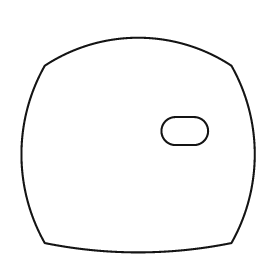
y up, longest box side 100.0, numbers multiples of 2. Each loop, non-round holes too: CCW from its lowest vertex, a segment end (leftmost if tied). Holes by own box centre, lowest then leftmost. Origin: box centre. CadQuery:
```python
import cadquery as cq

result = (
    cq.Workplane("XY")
    .moveTo(-40.0, -42.0)
    .threePointArc((0.0, -46.0), (40.0, -42.0))
    .threePointArc((50.0, -4.0), (40.0, 34.0))
    .threePointArc((0.0, 46.0), (-40.0, 34.0))
    .threePointArc((-50.0, -4.0), (-40.0, -42.0))
    .close()
    .moveTo(16.0, 0.0)
    .lineTo(24.0, 0.0)
    .threePointArc((30.0, 6.0), (24.0, 12.0))
    .lineTo(16.0, 12.0)
    .threePointArc((10.0, 6.0), (16.0, 0.0))
    .close()
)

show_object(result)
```